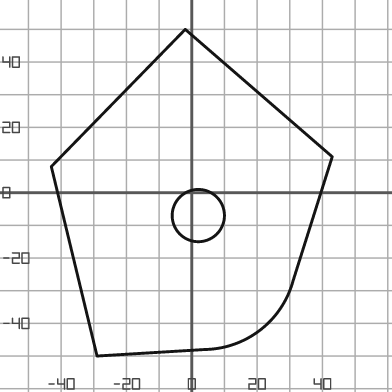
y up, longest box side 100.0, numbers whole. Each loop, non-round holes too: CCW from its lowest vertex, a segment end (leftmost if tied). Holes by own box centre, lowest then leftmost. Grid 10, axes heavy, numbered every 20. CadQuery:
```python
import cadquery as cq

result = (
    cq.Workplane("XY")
    .moveTo(-29.0, -50.0)
    .lineTo(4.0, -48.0)
    .threePointArc((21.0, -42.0), (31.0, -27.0))
    .lineTo(43.0, 11.0)
    .lineTo(-2.0, 50.0)
    .lineTo(-43.0, 8.0)
    .close()
    .moveTo(2.0, -7.0)
    .circle(8.0)
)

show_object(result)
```